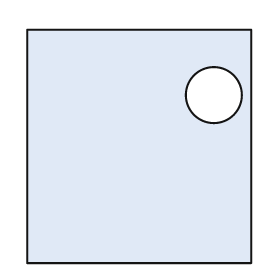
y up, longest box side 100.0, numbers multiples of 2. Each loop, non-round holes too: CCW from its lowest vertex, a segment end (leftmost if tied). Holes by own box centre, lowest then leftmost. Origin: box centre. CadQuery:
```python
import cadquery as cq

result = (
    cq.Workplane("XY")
    .moveTo(-48.0, -50.0)
    .lineTo(48.0, -50.0)
    .lineTo(48.0, 50.0)
    .lineTo(-48.0, 50.0)
    .close()
    .moveTo(32.0, 22.0)
    .circle(12.0)
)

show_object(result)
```